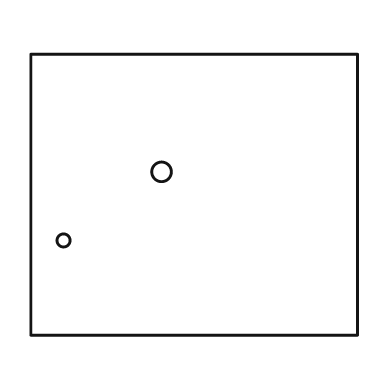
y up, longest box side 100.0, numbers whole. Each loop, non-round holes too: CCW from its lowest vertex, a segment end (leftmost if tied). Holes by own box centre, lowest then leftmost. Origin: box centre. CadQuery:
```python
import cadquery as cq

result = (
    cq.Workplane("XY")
    .moveTo(-50.0, -43.0)
    .lineTo(50.0, -43.0)
    .lineTo(50.0, 43.0)
    .lineTo(-50.0, 43.0)
    .close()
    .moveTo(-40.0, -14.0)
    .circle(2.0)
    .moveTo(-10.0, 7.0)
    .circle(3.0)
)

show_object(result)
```